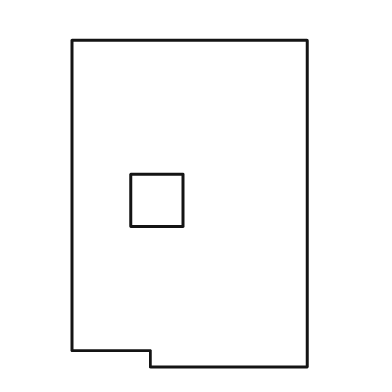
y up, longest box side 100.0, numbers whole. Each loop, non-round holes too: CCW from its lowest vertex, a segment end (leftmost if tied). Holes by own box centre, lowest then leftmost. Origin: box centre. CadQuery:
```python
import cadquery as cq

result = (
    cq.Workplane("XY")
    .moveTo(-12.0, -50.0)
    .lineTo(36.0, -50.0)
    .lineTo(36.0, 50.0)
    .lineTo(-36.0, 50.0)
    .lineTo(-36.0, -45.0)
    .lineTo(-12.0, -45.0)
    .close()
    .moveTo(-18.0, -7.0)
    .lineTo(-2.0, -7.0)
    .lineTo(-2.0, 9.0)
    .lineTo(-18.0, 9.0)
    .close()
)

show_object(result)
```